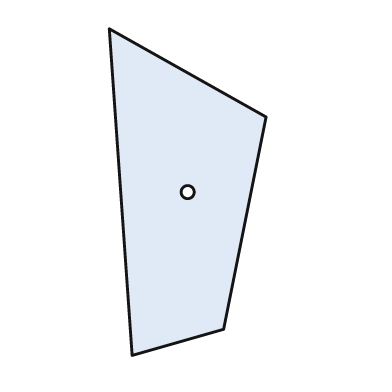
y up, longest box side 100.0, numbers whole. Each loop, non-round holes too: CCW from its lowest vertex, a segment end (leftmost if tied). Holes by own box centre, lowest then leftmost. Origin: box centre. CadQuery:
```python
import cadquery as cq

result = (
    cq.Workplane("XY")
    .moveTo(-17.0, -50.0)
    .lineTo(11.0, -42.0)
    .lineTo(24.0, 23.0)
    .lineTo(-24.0, 50.0)
    .close()
    .moveTo(0.0, 0.0)
    .circle(2.0)
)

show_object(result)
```